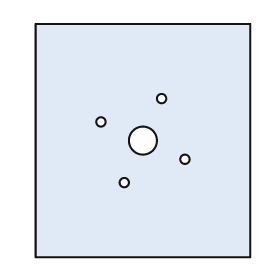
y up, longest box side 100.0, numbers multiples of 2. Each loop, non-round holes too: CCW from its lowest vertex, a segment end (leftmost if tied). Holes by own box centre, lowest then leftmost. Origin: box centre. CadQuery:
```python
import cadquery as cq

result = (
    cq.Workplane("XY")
    .moveTo(-46.0, -50.0)
    .lineTo(46.0, -50.0)
    .lineTo(46.0, 50.0)
    .lineTo(-46.0, 50.0)
    .close()
    .moveTo(-8.0, -18.0)
    .circle(2.0)
    .moveTo(18.0, -8.0)
    .circle(2.0)
    .moveTo(0.0, 0.0)
    .circle(6.0)
    .moveTo(-18.0, 8.0)
    .circle(2.0)
    .moveTo(8.0, 18.0)
    .circle(2.0)
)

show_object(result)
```